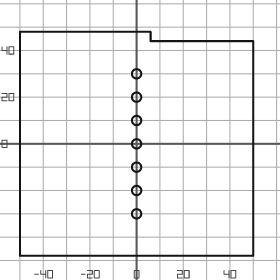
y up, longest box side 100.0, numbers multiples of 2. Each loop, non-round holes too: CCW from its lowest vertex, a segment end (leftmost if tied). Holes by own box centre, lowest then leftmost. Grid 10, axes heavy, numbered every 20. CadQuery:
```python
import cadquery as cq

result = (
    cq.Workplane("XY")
    .moveTo(-50.0, -48.0)
    .lineTo(50.0, -48.0)
    .lineTo(50.0, 44.0)
    .lineTo(6.0, 44.0)
    .lineTo(6.0, 48.0)
    .lineTo(-50.0, 48.0)
    .close()
    .moveTo(0.0, -30.0)
    .circle(2.0)
    .moveTo(0.0, -20.0)
    .circle(2.0)
    .moveTo(0.0, -10.0)
    .circle(2.0)
    .moveTo(0.0, 0.0)
    .circle(2.0)
    .moveTo(0.0, 10.0)
    .circle(2.0)
    .moveTo(0.0, 20.0)
    .circle(2.0)
    .moveTo(0.0, 30.0)
    .circle(2.0)
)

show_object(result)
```